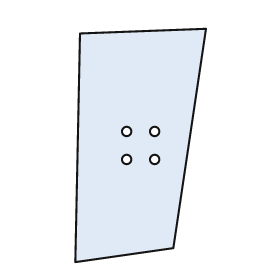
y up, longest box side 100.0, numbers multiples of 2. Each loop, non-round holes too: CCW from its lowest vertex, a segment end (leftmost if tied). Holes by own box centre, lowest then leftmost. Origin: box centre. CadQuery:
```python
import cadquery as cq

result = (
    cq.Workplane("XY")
    .moveTo(-28.0, -50.0)
    .lineTo(14.0, -44.0)
    .lineTo(28.0, 50.0)
    .lineTo(-26.0, 48.0)
    .close()
    .moveTo(-6.0, -6.0)
    .circle(2.0)
    .moveTo(6.0, -6.0)
    .circle(2.0)
    .moveTo(-6.0, 6.0)
    .circle(2.0)
    .moveTo(6.0, 6.0)
    .circle(2.0)
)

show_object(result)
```